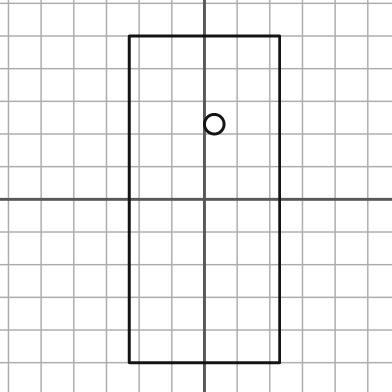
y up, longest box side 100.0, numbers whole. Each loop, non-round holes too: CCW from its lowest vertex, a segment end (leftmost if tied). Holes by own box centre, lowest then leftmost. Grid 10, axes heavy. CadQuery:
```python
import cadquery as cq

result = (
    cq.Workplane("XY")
    .moveTo(-23.0, -50.0)
    .lineTo(23.0, -50.0)
    .lineTo(23.0, 50.0)
    .lineTo(-23.0, 50.0)
    .close()
    .moveTo(3.0, 23.0)
    .circle(3.0)
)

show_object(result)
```